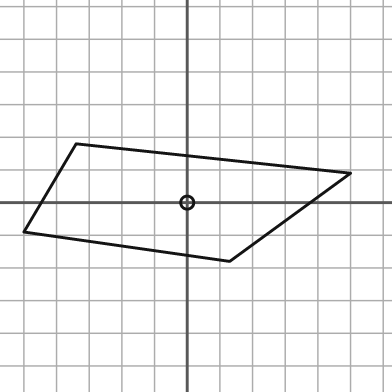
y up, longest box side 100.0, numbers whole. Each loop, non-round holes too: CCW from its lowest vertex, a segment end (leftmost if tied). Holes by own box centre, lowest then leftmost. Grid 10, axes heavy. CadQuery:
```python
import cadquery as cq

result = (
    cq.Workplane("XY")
    .moveTo(13.0, -18.0)
    .lineTo(50.0, 9.0)
    .lineTo(-34.0, 18.0)
    .lineTo(-50.0, -9.0)
    .close()
    .moveTo(0.0, 0.0)
    .circle(2.0)
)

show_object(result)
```